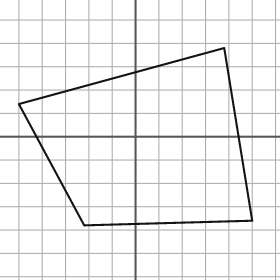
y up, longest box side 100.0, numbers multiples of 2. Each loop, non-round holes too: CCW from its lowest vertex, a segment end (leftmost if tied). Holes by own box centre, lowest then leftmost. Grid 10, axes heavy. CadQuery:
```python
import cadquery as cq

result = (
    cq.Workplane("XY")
    .moveTo(-22.0, -38.0)
    .lineTo(50.0, -36.0)
    .lineTo(38.0, 38.0)
    .lineTo(-50.0, 14.0)
    .close()
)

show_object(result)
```